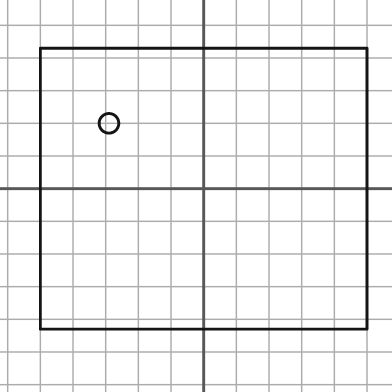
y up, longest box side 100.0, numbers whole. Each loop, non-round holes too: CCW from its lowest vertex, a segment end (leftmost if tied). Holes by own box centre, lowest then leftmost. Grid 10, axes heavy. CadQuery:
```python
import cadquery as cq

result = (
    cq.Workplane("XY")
    .moveTo(-50.0, -43.0)
    .lineTo(50.0, -43.0)
    .lineTo(50.0, 43.0)
    .lineTo(-50.0, 43.0)
    .close()
    .moveTo(-29.0, 20.0)
    .circle(3.0)
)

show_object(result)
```